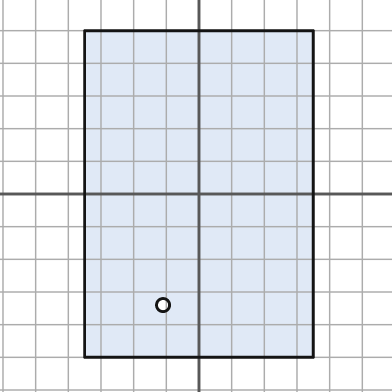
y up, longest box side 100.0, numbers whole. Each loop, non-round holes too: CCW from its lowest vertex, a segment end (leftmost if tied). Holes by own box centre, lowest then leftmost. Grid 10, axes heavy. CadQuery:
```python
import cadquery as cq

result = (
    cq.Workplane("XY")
    .moveTo(-35.0, -50.0)
    .lineTo(35.0, -50.0)
    .lineTo(35.0, 50.0)
    .lineTo(-35.0, 50.0)
    .close()
    .moveTo(-11.0, -34.0)
    .circle(2.0)
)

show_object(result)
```